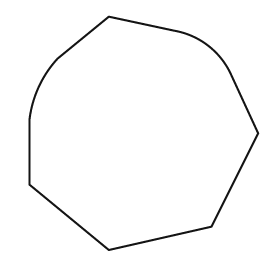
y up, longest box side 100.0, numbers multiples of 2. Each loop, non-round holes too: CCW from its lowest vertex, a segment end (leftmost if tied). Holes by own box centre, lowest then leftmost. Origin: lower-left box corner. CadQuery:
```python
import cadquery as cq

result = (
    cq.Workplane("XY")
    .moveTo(34.0, 0.0)
    .lineTo(78.0, 10.0)
    .lineTo(98.0, 50.0)
    .lineTo(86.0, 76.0)
    .threePointArc((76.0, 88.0), (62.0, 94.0))
    .lineTo(34.0, 100.0)
    .lineTo(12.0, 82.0)
    .threePointArc((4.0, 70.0), (0.0, 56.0))
    .lineTo(0.0, 28.0)
    .close()
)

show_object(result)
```